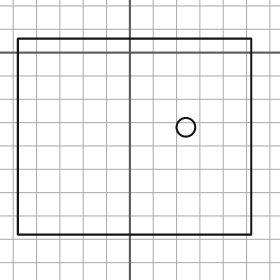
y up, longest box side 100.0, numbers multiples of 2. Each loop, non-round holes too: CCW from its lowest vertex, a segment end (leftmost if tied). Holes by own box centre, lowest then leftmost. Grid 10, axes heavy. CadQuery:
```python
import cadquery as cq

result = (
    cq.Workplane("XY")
    .moveTo(-48.0, -78.0)
    .lineTo(52.0, -78.0)
    .lineTo(52.0, 6.0)
    .lineTo(-48.0, 6.0)
    .close()
    .moveTo(24.0, -32.0)
    .circle(4.0)
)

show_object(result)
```